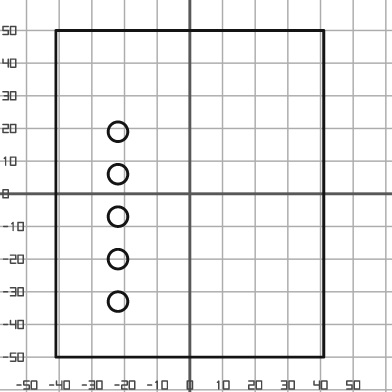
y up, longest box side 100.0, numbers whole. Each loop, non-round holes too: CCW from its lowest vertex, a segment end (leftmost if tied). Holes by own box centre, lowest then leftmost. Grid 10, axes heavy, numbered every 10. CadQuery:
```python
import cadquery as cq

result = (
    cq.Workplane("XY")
    .moveTo(-41.0, -50.0)
    .lineTo(41.0, -50.0)
    .lineTo(41.0, 50.0)
    .lineTo(-41.0, 50.0)
    .close()
    .moveTo(-22.0, -33.0)
    .circle(3.0)
    .moveTo(-22.0, -20.0)
    .circle(3.0)
    .moveTo(-22.0, -7.0)
    .circle(3.0)
    .moveTo(-22.0, 6.0)
    .circle(3.0)
    .moveTo(-22.0, 19.0)
    .circle(3.0)
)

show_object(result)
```